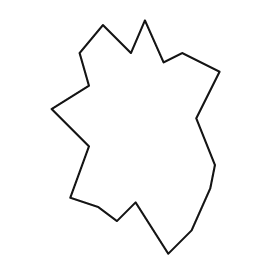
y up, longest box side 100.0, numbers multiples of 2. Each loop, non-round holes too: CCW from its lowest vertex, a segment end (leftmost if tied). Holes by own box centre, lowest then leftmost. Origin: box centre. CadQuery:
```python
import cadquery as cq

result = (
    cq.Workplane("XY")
    .moveTo(14.0, -50.0)
    .lineTo(24.0, -40.0)
    .lineTo(32.0, -22.0)
    .lineTo(34.0, -12.0)
    .lineTo(26.0, 8.0)
    .lineTo(36.0, 28.0)
    .lineTo(20.0, 36.0)
    .lineTo(12.0, 32.0)
    .lineTo(4.0, 50.0)
    .lineTo(-2.0, 36.0)
    .lineTo(-14.0, 48.0)
    .lineTo(-24.0, 36.0)
    .lineTo(-20.0, 22.0)
    .lineTo(-36.0, 12.0)
    .lineTo(-20.0, -4.0)
    .lineTo(-28.0, -26.0)
    .lineTo(-16.0, -30.0)
    .lineTo(-8.0, -36.0)
    .lineTo(0.0, -28.0)
    .close()
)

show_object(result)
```